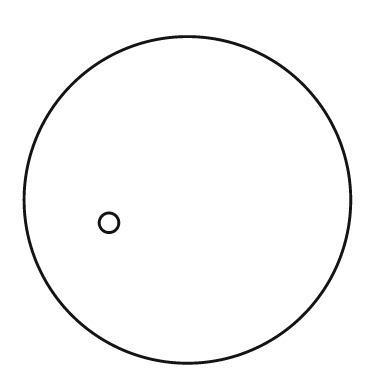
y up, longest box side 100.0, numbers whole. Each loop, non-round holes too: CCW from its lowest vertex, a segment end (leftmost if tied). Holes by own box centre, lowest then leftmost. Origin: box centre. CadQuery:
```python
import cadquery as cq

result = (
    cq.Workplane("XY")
    .moveTo(0.0, 0.0)
    .circle(50.0)
    .moveTo(-24.0, -7.0)
    .circle(3.0)
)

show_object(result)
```